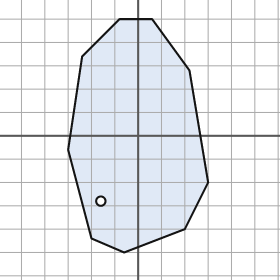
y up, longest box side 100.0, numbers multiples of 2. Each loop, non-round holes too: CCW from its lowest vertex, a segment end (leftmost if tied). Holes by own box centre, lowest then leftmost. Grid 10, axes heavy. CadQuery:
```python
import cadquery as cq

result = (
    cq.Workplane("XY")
    .moveTo(-6.0, -50.0)
    .lineTo(20.0, -40.0)
    .lineTo(30.0, -20.0)
    .lineTo(22.0, 28.0)
    .lineTo(6.0, 50.0)
    .lineTo(-8.0, 50.0)
    .lineTo(-24.0, 34.0)
    .lineTo(-30.0, -6.0)
    .lineTo(-20.0, -44.0)
    .close()
    .moveTo(-16.0, -28.0)
    .circle(2.0)
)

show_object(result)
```